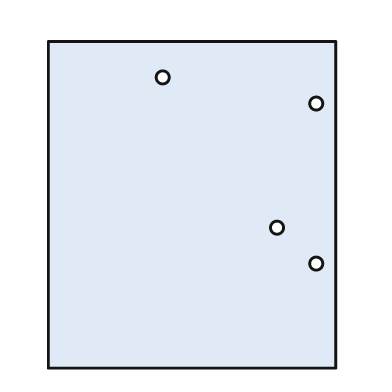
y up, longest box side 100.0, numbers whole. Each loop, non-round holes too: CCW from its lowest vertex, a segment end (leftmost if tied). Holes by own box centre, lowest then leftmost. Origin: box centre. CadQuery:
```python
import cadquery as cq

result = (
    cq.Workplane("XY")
    .moveTo(-44.0, -50.0)
    .lineTo(44.0, -50.0)
    .lineTo(44.0, 50.0)
    .lineTo(-44.0, 50.0)
    .close()
    .moveTo(38.0, -18.0)
    .circle(2.0)
    .moveTo(26.0, -7.0)
    .circle(2.0)
    .moveTo(38.0, 31.0)
    .circle(2.0)
    .moveTo(-9.0, 39.0)
    .circle(2.0)
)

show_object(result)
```